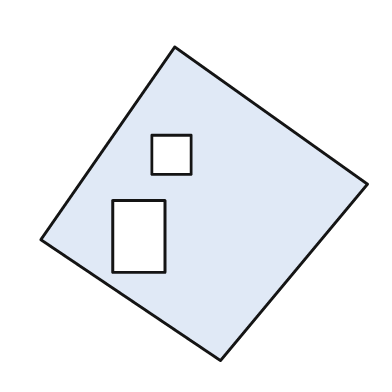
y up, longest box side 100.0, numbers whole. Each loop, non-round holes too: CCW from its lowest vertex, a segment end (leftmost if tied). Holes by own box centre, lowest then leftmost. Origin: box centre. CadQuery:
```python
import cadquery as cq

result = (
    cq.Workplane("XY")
    .moveTo(5.0, -48.0)
    .lineTo(50.0, 6.0)
    .lineTo(-9.0, 48.0)
    .lineTo(-50.0, -11.0)
    .close()
    .moveTo(-28.0, -21.0)
    .lineTo(-12.0, -21.0)
    .lineTo(-12.0, 1.0)
    .lineTo(-28.0, 1.0)
    .close()
    .moveTo(-16.0, 9.0)
    .lineTo(-4.0, 9.0)
    .lineTo(-4.0, 21.0)
    .lineTo(-16.0, 21.0)
    .close()
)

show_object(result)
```